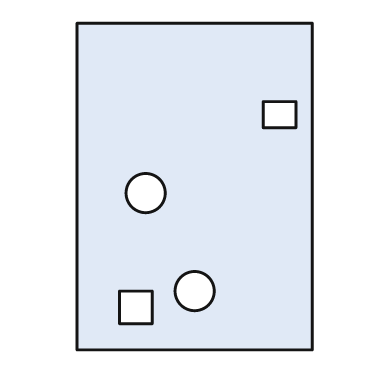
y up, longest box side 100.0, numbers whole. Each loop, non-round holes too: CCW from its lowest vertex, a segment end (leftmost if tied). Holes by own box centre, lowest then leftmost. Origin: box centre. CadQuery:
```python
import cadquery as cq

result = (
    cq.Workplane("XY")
    .moveTo(-36.0, -50.0)
    .lineTo(36.0, -50.0)
    .lineTo(36.0, 50.0)
    .lineTo(-36.0, 50.0)
    .close()
    .moveTo(-23.0, -42.0)
    .lineTo(-13.0, -42.0)
    .lineTo(-13.0, -32.0)
    .lineTo(-23.0, -32.0)
    .close()
    .moveTo(0.0, -32.0)
    .circle(6.0)
    .moveTo(-15.0, -2.0)
    .circle(6.0)
    .moveTo(21.0, 18.0)
    .lineTo(31.0, 18.0)
    .lineTo(31.0, 26.0)
    .lineTo(21.0, 26.0)
    .close()
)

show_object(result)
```